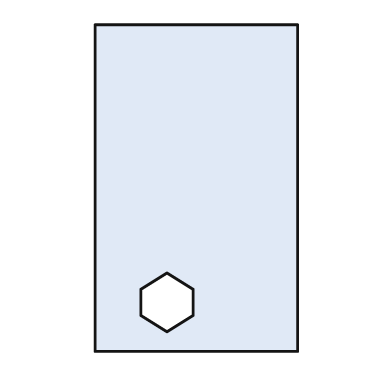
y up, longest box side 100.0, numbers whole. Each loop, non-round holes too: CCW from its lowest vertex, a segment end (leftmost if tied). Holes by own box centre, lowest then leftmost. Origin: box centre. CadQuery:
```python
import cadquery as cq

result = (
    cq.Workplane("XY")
    .moveTo(-31.0, -50.0)
    .lineTo(31.0, -50.0)
    .lineTo(31.0, 50.0)
    .lineTo(-31.0, 50.0)
    .close()
    .moveTo(-9.0, -44.0)
    .lineTo(-1.0, -39.0)
    .lineTo(-1.0, -31.0)
    .lineTo(-9.0, -26.0)
    .lineTo(-17.0, -31.0)
    .lineTo(-17.0, -39.0)
    .close()
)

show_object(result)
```